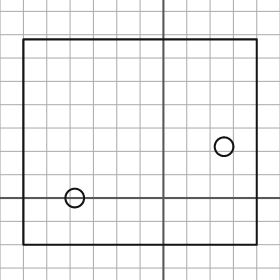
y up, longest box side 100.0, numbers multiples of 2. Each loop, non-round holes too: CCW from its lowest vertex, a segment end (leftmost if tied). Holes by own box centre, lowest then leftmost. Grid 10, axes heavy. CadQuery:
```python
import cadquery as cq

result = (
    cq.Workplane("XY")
    .moveTo(-60.0, -20.0)
    .lineTo(40.0, -20.0)
    .lineTo(40.0, 68.0)
    .lineTo(-60.0, 68.0)
    .close()
    .moveTo(-38.0, 0.0)
    .circle(4.0)
    .moveTo(26.0, 22.0)
    .circle(4.0)
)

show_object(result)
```